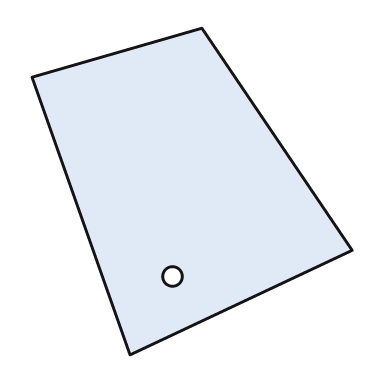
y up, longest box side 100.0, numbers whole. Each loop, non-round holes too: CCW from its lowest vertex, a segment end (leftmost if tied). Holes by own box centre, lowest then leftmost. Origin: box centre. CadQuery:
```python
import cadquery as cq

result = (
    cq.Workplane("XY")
    .moveTo(-19.0, -50.0)
    .lineTo(49.0, -18.0)
    .lineTo(3.0, 50.0)
    .lineTo(-49.0, 35.0)
    .close()
    .moveTo(-6.0, -26.0)
    .circle(3.0)
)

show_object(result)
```